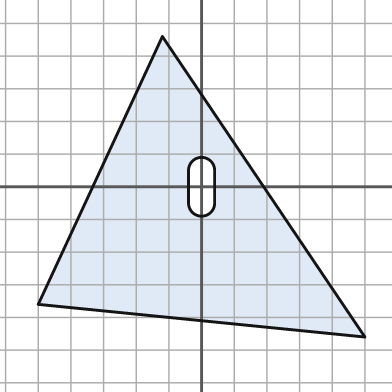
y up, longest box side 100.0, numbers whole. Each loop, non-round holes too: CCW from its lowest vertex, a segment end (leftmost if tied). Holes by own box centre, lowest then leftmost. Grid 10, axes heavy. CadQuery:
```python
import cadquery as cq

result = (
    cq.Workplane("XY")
    .moveTo(50.0, -46.0)
    .lineTo(-12.0, 46.0)
    .lineTo(-50.0, -36.0)
    .close()
    .moveTo(-4.0, -5.0)
    .threePointArc((0.0, -9.0), (4.0, -5.0))
    .lineTo(4.0, 5.0)
    .threePointArc((0.0, 9.0), (-4.0, 5.0))
    .close()
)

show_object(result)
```